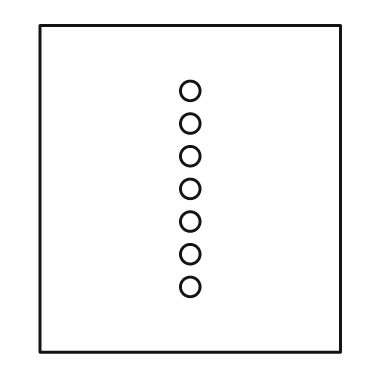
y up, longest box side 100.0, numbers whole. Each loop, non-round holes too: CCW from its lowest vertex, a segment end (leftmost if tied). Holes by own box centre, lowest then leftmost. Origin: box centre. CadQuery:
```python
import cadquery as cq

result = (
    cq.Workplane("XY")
    .moveTo(-46.0, -50.0)
    .lineTo(46.0, -50.0)
    .lineTo(46.0, 50.0)
    .lineTo(-46.0, 50.0)
    .close()
    .moveTo(0.0, -30.0)
    .circle(3.0)
    .moveTo(0.0, -20.0)
    .circle(3.0)
    .moveTo(0.0, -10.0)
    .circle(3.0)
    .moveTo(0.0, 0.0)
    .circle(3.0)
    .moveTo(0.0, 10.0)
    .circle(3.0)
    .moveTo(0.0, 20.0)
    .circle(3.0)
    .moveTo(0.0, 30.0)
    .circle(3.0)
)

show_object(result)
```